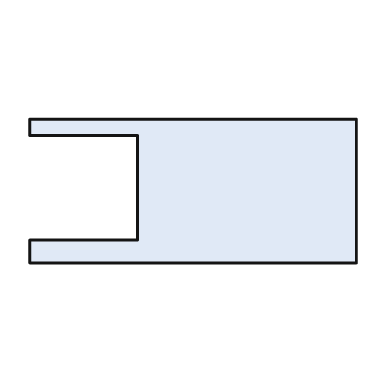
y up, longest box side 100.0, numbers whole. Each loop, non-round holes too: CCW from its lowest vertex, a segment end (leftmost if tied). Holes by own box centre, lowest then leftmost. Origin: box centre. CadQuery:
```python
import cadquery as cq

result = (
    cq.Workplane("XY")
    .moveTo(-50.0, -22.0)
    .lineTo(50.0, -22.0)
    .lineTo(50.0, 22.0)
    .lineTo(-50.0, 22.0)
    .lineTo(-50.0, 17.0)
    .lineTo(-17.0, 17.0)
    .lineTo(-17.0, -15.0)
    .lineTo(-50.0, -15.0)
    .close()
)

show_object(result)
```